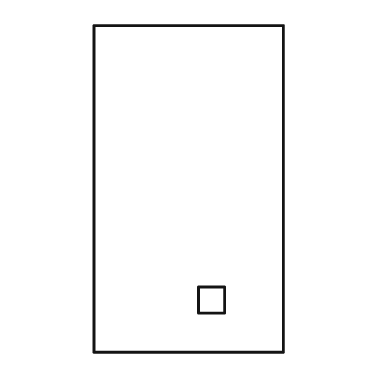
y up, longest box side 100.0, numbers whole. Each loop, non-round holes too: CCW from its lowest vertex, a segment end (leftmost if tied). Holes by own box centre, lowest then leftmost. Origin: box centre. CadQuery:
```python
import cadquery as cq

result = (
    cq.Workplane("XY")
    .moveTo(-29.0, -50.0)
    .lineTo(29.0, -50.0)
    .lineTo(29.0, 50.0)
    .lineTo(-29.0, 50.0)
    .close()
    .moveTo(3.0, -38.0)
    .lineTo(11.0, -38.0)
    .lineTo(11.0, -30.0)
    .lineTo(3.0, -30.0)
    .close()
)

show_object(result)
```